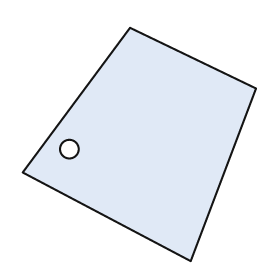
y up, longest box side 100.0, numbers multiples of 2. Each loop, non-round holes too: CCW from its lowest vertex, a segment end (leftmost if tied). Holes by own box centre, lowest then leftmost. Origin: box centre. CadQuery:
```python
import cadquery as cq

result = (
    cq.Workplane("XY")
    .moveTo(22.0, -50.0)
    .lineTo(50.0, 24.0)
    .lineTo(-4.0, 50.0)
    .lineTo(-50.0, -12.0)
    .close()
    .moveTo(-30.0, -2.0)
    .circle(4.0)
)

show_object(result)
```